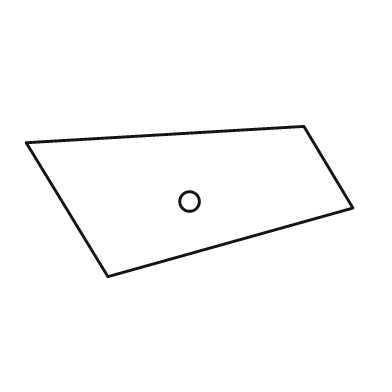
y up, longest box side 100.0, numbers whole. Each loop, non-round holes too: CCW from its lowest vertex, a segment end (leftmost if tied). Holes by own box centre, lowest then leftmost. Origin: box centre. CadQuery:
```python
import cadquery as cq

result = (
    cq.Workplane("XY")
    .moveTo(-25.0, -23.0)
    .lineTo(50.0, -2.0)
    .lineTo(35.0, 23.0)
    .lineTo(-50.0, 18.0)
    .close()
    .moveTo(0.0, 0.0)
    .circle(3.0)
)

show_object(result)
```